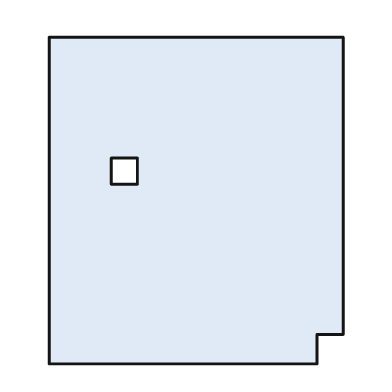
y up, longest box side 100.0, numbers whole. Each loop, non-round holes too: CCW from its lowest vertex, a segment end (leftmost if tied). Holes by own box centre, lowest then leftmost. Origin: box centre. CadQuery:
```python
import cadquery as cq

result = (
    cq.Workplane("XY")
    .moveTo(-45.0, -50.0)
    .lineTo(37.0, -50.0)
    .lineTo(37.0, -41.0)
    .lineTo(45.0, -41.0)
    .lineTo(45.0, 50.0)
    .lineTo(-45.0, 50.0)
    .close()
    .moveTo(-26.0, 5.0)
    .lineTo(-18.0, 5.0)
    .lineTo(-18.0, 13.0)
    .lineTo(-26.0, 13.0)
    .close()
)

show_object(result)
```